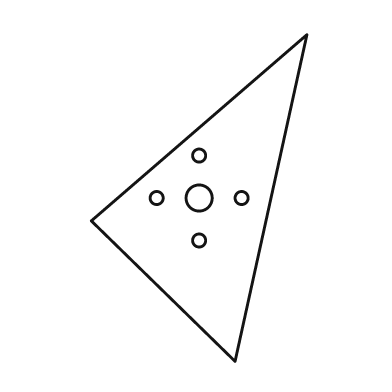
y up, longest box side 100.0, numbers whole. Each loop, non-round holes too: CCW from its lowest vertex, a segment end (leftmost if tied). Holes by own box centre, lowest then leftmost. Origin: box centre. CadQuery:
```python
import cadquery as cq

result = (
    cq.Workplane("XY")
    .moveTo(11.0, -50.0)
    .lineTo(33.0, 50.0)
    .lineTo(-33.0, -7.0)
    .close()
    .moveTo(0.0, -13.0)
    .circle(2.0)
    .moveTo(-13.0, 0.0)
    .circle(2.0)
    .moveTo(0.0, 0.0)
    .circle(4.0)
    .moveTo(13.0, 0.0)
    .circle(2.0)
    .moveTo(0.0, 13.0)
    .circle(2.0)
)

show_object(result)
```